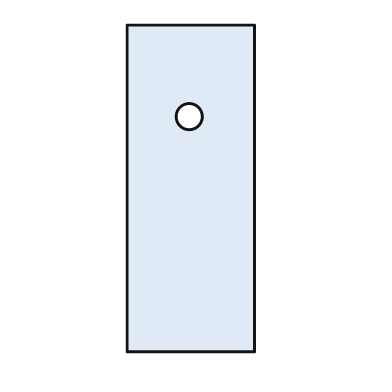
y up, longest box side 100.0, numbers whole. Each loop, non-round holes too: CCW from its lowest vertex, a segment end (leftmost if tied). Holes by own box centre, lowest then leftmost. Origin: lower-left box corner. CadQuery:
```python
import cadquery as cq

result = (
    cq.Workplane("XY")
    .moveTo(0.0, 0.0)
    .lineTo(39.0, 0.0)
    .lineTo(39.0, 100.0)
    .lineTo(0.0, 100.0)
    .close()
    .moveTo(19.0, 72.0)
    .circle(4.0)
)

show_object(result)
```